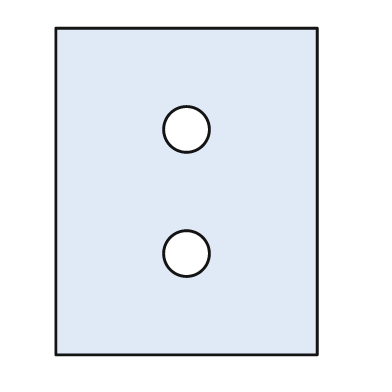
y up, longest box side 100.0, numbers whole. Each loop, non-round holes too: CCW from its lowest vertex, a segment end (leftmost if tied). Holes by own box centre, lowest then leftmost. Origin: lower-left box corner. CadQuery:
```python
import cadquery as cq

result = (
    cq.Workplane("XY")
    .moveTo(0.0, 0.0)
    .lineTo(80.0, 0.0)
    .lineTo(80.0, 100.0)
    .lineTo(0.0, 100.0)
    .close()
    .moveTo(40.0, 31.0)
    .circle(7.0)
    .moveTo(40.0, 69.0)
    .circle(7.0)
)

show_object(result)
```